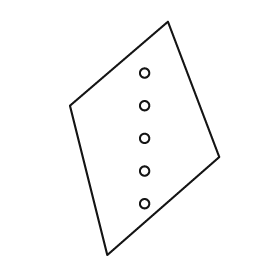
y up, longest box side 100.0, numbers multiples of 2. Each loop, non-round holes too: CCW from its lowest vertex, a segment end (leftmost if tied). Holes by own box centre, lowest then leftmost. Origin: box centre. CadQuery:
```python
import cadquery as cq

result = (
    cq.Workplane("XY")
    .moveTo(-16.0, -50.0)
    .lineTo(32.0, -8.0)
    .lineTo(10.0, 50.0)
    .lineTo(-32.0, 14.0)
    .close()
    .moveTo(0.0, -28.0)
    .circle(2.0)
    .moveTo(0.0, -14.0)
    .circle(2.0)
    .moveTo(0.0, 0.0)
    .circle(2.0)
    .moveTo(0.0, 14.0)
    .circle(2.0)
    .moveTo(0.0, 28.0)
    .circle(2.0)
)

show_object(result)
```